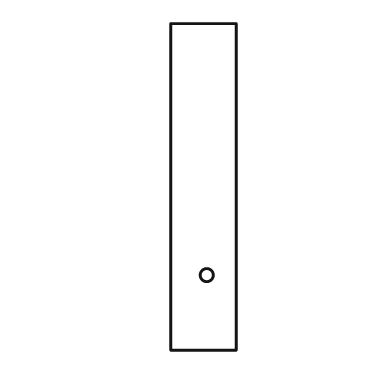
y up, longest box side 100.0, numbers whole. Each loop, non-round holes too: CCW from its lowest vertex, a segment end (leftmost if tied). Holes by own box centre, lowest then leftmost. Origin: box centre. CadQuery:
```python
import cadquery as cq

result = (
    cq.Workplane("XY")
    .moveTo(-10.0, -50.0)
    .lineTo(10.0, -50.0)
    .lineTo(10.0, 50.0)
    .lineTo(-10.0, 50.0)
    .close()
    .moveTo(1.0, -27.0)
    .circle(2.0)
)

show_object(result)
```